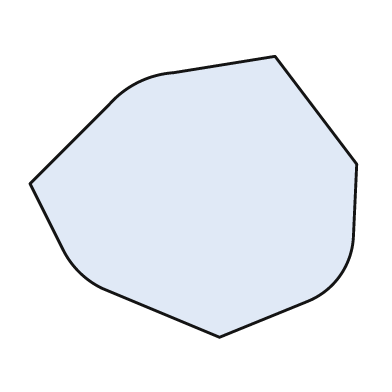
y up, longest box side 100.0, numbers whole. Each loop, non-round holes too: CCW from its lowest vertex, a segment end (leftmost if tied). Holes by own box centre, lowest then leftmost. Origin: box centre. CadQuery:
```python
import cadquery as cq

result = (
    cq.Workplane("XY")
    .moveTo(8.0, -43.0)
    .lineTo(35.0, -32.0)
    .threePointArc((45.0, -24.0), (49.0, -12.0))
    .lineTo(50.0, 10.0)
    .lineTo(25.0, 43.0)
    .lineTo(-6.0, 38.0)
    .threePointArc((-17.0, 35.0), (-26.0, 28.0))
    .lineTo(-50.0, 4.0)
    .lineTo(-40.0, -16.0)
    .threePointArc((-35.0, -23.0), (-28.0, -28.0))
    .close()
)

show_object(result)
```